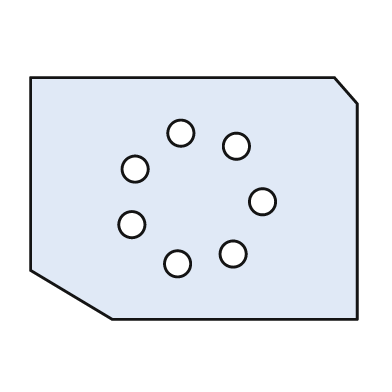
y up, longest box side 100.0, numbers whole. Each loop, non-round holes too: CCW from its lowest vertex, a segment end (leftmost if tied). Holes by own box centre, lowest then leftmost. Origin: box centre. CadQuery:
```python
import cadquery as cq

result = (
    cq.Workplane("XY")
    .moveTo(-25.0, -37.0)
    .lineTo(50.0, -37.0)
    .lineTo(50.0, 29.0)
    .lineTo(43.0, 37.0)
    .lineTo(-50.0, 37.0)
    .lineTo(-50.0, -22.0)
    .close()
    .moveTo(-5.0, -20.0)
    .circle(4.0)
    .moveTo(12.0, -17.0)
    .circle(4.0)
    .moveTo(-19.0, -8.0)
    .circle(4.0)
    .moveTo(21.0, -1.0)
    .circle(4.0)
    .moveTo(-18.0, 9.0)
    .circle(4.0)
    .moveTo(13.0, 16.0)
    .circle(4.0)
    .moveTo(-4.0, 20.0)
    .circle(4.0)
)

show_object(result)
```